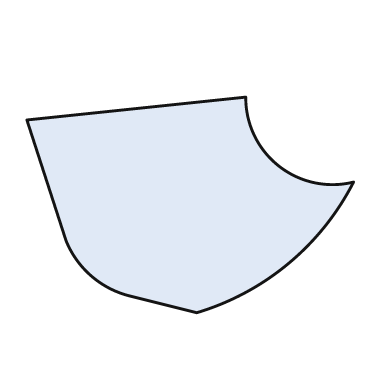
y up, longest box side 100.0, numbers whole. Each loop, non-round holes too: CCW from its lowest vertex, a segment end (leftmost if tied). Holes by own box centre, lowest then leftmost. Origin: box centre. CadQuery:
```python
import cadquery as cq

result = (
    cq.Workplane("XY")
    .moveTo(2.0, -33.0)
    .threePointArc((30.0, -18.0), (50.0, 7.0))
    .threePointArc((27.0, 12.0), (17.0, 33.0))
    .lineTo(-50.0, 26.0)
    .lineTo(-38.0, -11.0)
    .threePointArc((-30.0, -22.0), (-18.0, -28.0))
    .close()
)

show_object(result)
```